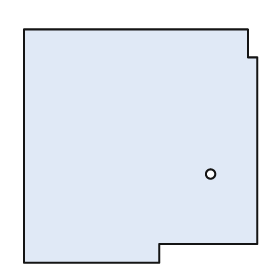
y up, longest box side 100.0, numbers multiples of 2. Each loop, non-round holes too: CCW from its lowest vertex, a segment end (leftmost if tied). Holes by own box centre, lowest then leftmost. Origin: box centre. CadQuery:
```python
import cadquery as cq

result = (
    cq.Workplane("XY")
    .moveTo(-50.0, -50.0)
    .lineTo(8.0, -50.0)
    .lineTo(8.0, -42.0)
    .lineTo(50.0, -42.0)
    .lineTo(50.0, 38.0)
    .lineTo(46.0, 38.0)
    .lineTo(46.0, 50.0)
    .lineTo(-50.0, 50.0)
    .close()
    .moveTo(30.0, -12.0)
    .circle(2.0)
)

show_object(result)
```